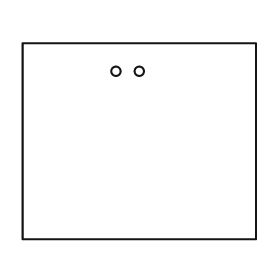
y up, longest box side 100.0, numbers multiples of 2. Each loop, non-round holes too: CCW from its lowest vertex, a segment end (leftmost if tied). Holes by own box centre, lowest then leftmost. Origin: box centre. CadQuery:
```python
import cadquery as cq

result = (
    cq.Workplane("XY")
    .moveTo(-50.0, -42.0)
    .lineTo(50.0, -42.0)
    .lineTo(50.0, 42.0)
    .lineTo(-50.0, 42.0)
    .close()
    .moveTo(-10.0, 30.0)
    .circle(2.0)
    .moveTo(0.0, 30.0)
    .circle(2.0)
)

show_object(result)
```